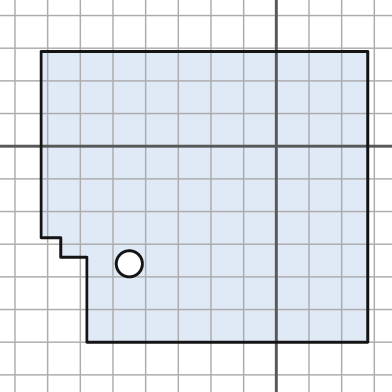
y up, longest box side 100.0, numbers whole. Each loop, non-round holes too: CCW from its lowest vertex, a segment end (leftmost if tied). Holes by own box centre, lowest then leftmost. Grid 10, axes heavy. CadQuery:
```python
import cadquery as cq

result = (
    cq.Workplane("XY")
    .moveTo(-58.0, -60.0)
    .lineTo(28.0, -60.0)
    .lineTo(28.0, 29.0)
    .lineTo(-72.0, 29.0)
    .lineTo(-72.0, -28.0)
    .lineTo(-66.0, -28.0)
    .lineTo(-66.0, -34.0)
    .lineTo(-58.0, -34.0)
    .close()
    .moveTo(-45.0, -36.0)
    .circle(4.0)
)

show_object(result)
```